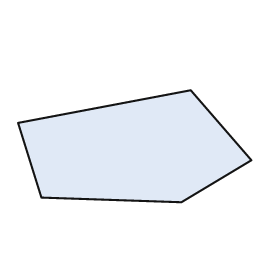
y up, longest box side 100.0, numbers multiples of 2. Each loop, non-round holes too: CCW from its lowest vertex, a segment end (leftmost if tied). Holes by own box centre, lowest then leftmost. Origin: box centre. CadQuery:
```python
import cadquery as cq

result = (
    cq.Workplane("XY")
    .moveTo(20.0, -24.0)
    .lineTo(50.0, -6.0)
    .lineTo(24.0, 24.0)
    .lineTo(-50.0, 10.0)
    .lineTo(-40.0, -22.0)
    .close()
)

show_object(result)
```